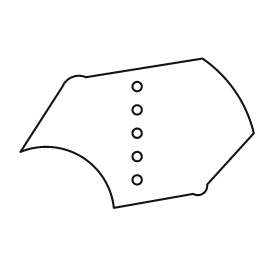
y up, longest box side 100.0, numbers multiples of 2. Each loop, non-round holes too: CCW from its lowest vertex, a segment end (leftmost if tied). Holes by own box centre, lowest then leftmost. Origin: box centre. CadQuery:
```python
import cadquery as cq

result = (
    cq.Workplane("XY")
    .moveTo(-10.0, -32.0)
    .lineTo(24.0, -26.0)
    .threePointArc((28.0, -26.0), (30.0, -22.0))
    .lineTo(50.0, 0.0)
    .threePointArc((42.0, 18.0), (28.0, 32.0))
    .lineTo(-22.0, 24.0)
    .threePointArc((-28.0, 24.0), (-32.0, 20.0))
    .lineTo(-50.0, -8.0)
    .threePointArc((-24.0, -10.0), (-10.0, -32.0))
    .close()
    .moveTo(0.0, -20.0)
    .circle(2.0)
    .moveTo(0.0, -10.0)
    .circle(2.0)
    .moveTo(0.0, 0.0)
    .circle(2.0)
    .moveTo(0.0, 10.0)
    .circle(2.0)
    .moveTo(0.0, 20.0)
    .circle(2.0)
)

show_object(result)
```